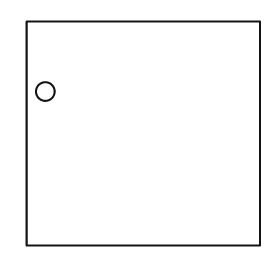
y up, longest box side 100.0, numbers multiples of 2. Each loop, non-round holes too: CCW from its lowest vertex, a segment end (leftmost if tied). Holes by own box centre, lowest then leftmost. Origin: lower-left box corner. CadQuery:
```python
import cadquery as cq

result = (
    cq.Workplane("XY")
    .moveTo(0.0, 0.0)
    .lineTo(100.0, 0.0)
    .lineTo(100.0, 96.0)
    .lineTo(0.0, 96.0)
    .close()
    .moveTo(8.0, 66.0)
    .circle(4.0)
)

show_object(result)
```